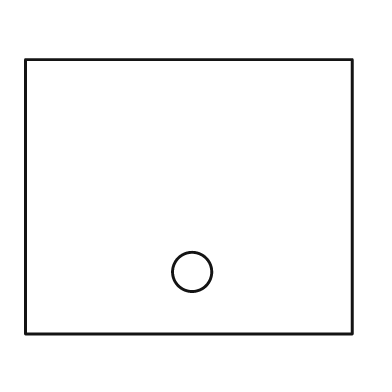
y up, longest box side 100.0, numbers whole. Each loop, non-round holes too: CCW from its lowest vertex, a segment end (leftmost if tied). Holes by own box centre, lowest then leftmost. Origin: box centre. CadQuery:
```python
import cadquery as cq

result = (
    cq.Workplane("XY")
    .moveTo(-50.0, -42.0)
    .lineTo(50.0, -42.0)
    .lineTo(50.0, 42.0)
    .lineTo(-50.0, 42.0)
    .close()
    .moveTo(1.0, -23.0)
    .circle(6.0)
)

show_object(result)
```